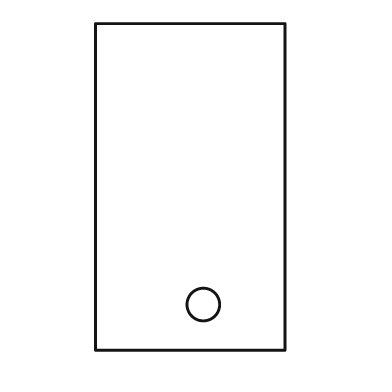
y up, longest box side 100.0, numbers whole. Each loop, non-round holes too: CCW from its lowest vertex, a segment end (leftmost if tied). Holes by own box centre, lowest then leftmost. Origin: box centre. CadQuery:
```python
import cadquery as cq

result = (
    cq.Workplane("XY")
    .moveTo(-29.0, -50.0)
    .lineTo(29.0, -50.0)
    .lineTo(29.0, 50.0)
    .lineTo(-29.0, 50.0)
    .close()
    .moveTo(4.0, -36.0)
    .circle(5.0)
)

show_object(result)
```